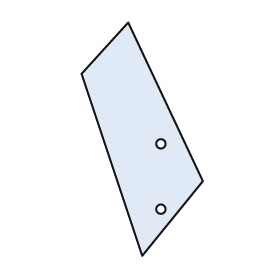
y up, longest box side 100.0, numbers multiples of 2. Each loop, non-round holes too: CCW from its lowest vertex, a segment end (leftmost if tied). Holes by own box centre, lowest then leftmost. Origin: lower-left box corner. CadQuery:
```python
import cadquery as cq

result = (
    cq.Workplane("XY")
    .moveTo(26.0, 0.0)
    .lineTo(52.0, 32.0)
    .lineTo(20.0, 100.0)
    .lineTo(0.0, 78.0)
    .close()
    .moveTo(34.0, 20.0)
    .circle(2.0)
    .moveTo(34.0, 48.0)
    .circle(2.0)
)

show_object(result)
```